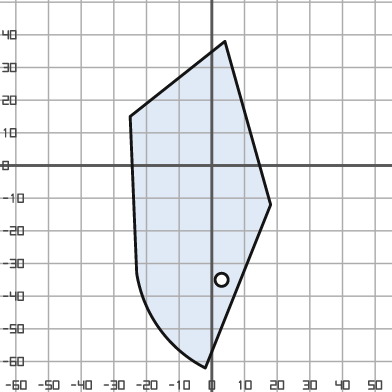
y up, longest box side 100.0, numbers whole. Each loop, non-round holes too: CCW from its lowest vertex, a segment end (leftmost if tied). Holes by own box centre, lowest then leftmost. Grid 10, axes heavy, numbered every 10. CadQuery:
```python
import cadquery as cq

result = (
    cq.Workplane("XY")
    .moveTo(-2.0, -62.0)
    .lineTo(18.0, -12.0)
    .lineTo(4.0, 38.0)
    .lineTo(-25.0, 15.0)
    .lineTo(-23.0, -33.0)
    .threePointArc((-16.0, -50.0), (-2.0, -62.0))
    .close()
    .moveTo(3.0, -35.0)
    .circle(2.0)
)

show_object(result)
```